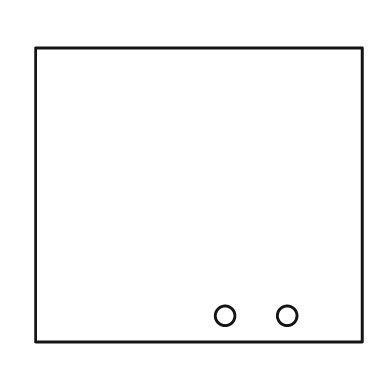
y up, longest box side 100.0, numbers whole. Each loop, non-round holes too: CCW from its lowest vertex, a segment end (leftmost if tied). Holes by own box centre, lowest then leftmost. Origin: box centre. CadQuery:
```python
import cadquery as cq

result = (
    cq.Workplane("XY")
    .moveTo(-50.0, -45.0)
    .lineTo(50.0, -45.0)
    .lineTo(50.0, 45.0)
    .lineTo(-50.0, 45.0)
    .close()
    .moveTo(8.0, -37.0)
    .circle(3.0)
    .moveTo(27.0, -37.0)
    .circle(3.0)
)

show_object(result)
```